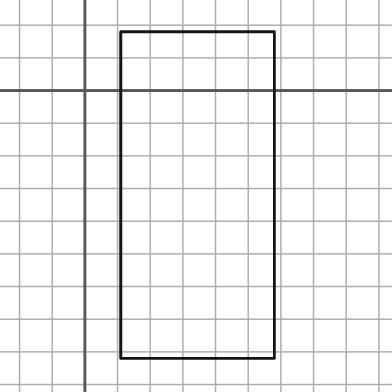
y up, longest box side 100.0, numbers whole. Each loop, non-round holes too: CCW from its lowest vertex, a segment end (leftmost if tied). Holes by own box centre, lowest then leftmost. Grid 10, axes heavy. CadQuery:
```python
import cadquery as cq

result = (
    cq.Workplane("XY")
    .moveTo(11.0, -82.0)
    .lineTo(58.0, -82.0)
    .lineTo(58.0, 18.0)
    .lineTo(11.0, 18.0)
    .close()
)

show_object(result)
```